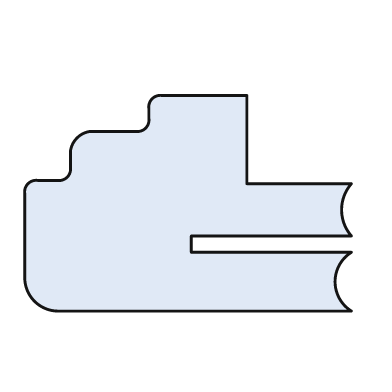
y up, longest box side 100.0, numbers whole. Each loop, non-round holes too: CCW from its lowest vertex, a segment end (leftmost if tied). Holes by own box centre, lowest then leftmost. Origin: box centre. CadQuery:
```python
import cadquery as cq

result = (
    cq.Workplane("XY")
    .moveTo(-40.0, -33.0)
    .lineTo(50.0, -33.0)
    .threePointArc((45.0, -24.0), (50.0, -15.0))
    .lineTo(1.0, -15.0)
    .lineTo(1.0, -10.0)
    .lineTo(50.0, -10.0)
    .threePointArc((47.0, -2.0), (50.0, 6.0))
    .lineTo(18.0, 6.0)
    .lineTo(18.0, 33.0)
    .lineTo(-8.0, 33.0)
    .threePointArc((-11.0, 32.0), (-12.0, 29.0))
    .lineTo(-12.0, 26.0)
    .threePointArc((-13.0, 23.0), (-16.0, 22.0))
    .lineTo(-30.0, 22.0)
    .threePointArc((-34.0, 20.0), (-36.0, 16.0))
    .lineTo(-36.0, 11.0)
    .threePointArc((-37.0, 8.0), (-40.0, 7.0))
    .lineTo(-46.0, 7.0)
    .threePointArc((-49.0, 6.0), (-50.0, 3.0))
    .lineTo(-50.0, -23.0)
    .threePointArc((-47.0, -30.0), (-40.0, -33.0))
    .close()
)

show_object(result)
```